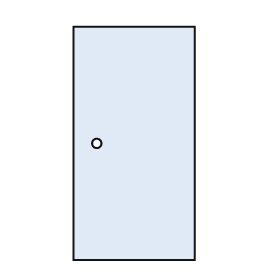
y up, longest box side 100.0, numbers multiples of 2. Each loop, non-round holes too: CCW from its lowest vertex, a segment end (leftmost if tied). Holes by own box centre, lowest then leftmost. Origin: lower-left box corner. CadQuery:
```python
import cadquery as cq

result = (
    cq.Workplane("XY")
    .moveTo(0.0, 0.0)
    .lineTo(52.0, 0.0)
    .lineTo(52.0, 100.0)
    .lineTo(0.0, 100.0)
    .close()
    .moveTo(10.0, 50.0)
    .circle(2.0)
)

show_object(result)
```